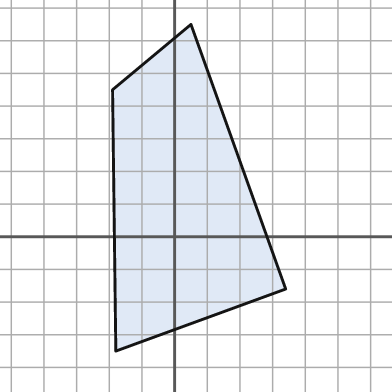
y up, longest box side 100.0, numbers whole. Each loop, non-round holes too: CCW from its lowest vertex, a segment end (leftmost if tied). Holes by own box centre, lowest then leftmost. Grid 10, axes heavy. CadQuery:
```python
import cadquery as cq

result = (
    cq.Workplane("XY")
    .moveTo(-18.0, -35.0)
    .lineTo(34.0, -16.0)
    .lineTo(5.0, 65.0)
    .lineTo(-19.0, 45.0)
    .close()
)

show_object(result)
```